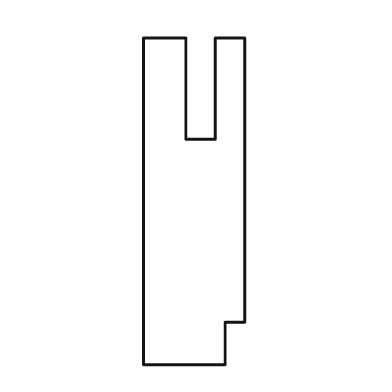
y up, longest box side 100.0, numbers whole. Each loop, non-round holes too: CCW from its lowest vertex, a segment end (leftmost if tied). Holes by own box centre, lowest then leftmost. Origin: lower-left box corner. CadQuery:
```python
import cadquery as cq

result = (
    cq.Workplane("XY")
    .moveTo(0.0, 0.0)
    .lineTo(25.0, 0.0)
    .lineTo(25.0, 13.0)
    .lineTo(31.0, 13.0)
    .lineTo(31.0, 100.0)
    .lineTo(22.0, 100.0)
    .lineTo(22.0, 69.0)
    .lineTo(13.0, 69.0)
    .lineTo(13.0, 100.0)
    .lineTo(0.0, 100.0)
    .close()
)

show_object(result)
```